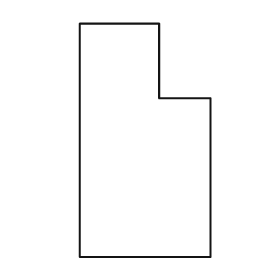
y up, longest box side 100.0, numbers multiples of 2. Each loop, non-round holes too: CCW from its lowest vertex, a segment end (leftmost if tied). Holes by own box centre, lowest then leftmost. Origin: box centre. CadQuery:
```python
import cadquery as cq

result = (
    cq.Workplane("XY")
    .moveTo(-28.0, -50.0)
    .lineTo(28.0, -50.0)
    .lineTo(28.0, 18.0)
    .lineTo(6.0, 18.0)
    .lineTo(6.0, 50.0)
    .lineTo(-28.0, 50.0)
    .close()
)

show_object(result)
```